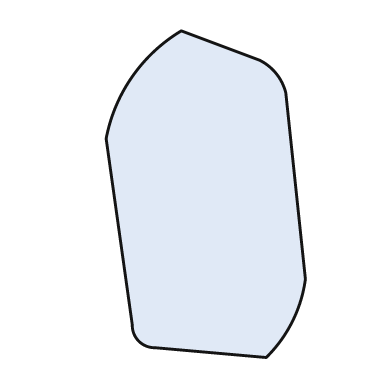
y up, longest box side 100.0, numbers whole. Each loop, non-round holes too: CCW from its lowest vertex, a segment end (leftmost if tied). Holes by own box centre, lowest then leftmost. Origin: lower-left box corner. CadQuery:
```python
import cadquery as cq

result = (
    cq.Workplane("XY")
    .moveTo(49.0, 0.0)
    .threePointArc((57.0, 11.0), (61.0, 24.0))
    .lineTo(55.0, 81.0)
    .threePointArc((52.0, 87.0), (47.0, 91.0))
    .lineTo(23.0, 100.0)
    .threePointArc((8.0, 86.0), (0.0, 67.0))
    .lineTo(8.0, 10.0)
    .threePointArc((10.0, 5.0), (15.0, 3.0))
    .close()
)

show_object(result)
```